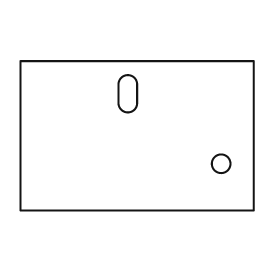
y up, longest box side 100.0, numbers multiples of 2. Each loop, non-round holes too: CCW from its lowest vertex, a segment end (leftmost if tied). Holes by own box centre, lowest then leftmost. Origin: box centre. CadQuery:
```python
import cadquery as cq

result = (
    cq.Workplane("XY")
    .moveTo(-50.0, -32.0)
    .lineTo(50.0, -32.0)
    .lineTo(50.0, 32.0)
    .lineTo(-50.0, 32.0)
    .close()
    .moveTo(36.0, -12.0)
    .circle(4.0)
    .moveTo(-8.0, 14.0)
    .threePointArc((-4.0, 10.0), (0.0, 14.0))
    .lineTo(0.0, 22.0)
    .threePointArc((-4.0, 26.0), (-8.0, 22.0))
    .close()
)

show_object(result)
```